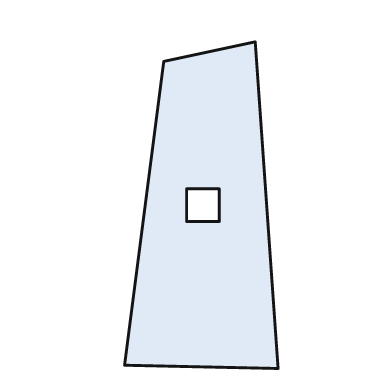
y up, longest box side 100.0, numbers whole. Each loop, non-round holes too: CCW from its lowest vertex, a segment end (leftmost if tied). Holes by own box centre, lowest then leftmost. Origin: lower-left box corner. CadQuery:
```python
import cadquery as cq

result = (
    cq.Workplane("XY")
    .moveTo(47.0, 0.0)
    .lineTo(40.0, 100.0)
    .lineTo(12.0, 94.0)
    .lineTo(0.0, 1.0)
    .close()
    .moveTo(19.0, 45.0)
    .lineTo(29.0, 45.0)
    .lineTo(29.0, 55.0)
    .lineTo(19.0, 55.0)
    .close()
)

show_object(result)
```